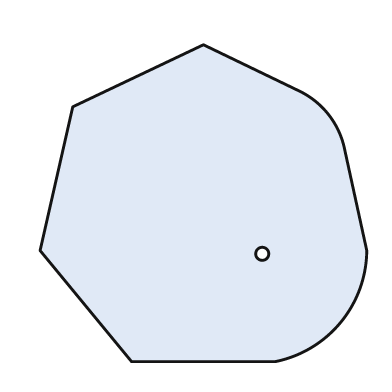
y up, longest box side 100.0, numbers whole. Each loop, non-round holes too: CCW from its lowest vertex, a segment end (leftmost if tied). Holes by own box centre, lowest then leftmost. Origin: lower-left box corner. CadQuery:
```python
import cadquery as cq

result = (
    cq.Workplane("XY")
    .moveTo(28.0, 0.0)
    .lineTo(72.0, 0.0)
    .threePointArc((92.0, 12.0), (100.0, 34.0))
    .lineTo(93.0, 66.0)
    .threePointArc((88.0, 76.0), (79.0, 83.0))
    .lineTo(50.0, 97.0)
    .lineTo(10.0, 78.0)
    .lineTo(0.0, 34.0)
    .close()
    .moveTo(68.0, 33.0)
    .circle(2.0)
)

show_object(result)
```